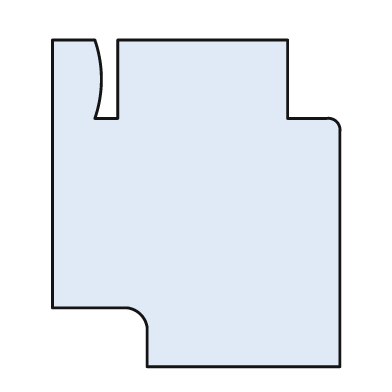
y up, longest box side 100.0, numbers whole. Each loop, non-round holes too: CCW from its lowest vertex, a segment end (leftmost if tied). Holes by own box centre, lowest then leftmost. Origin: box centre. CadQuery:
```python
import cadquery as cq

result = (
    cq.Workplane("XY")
    .moveTo(-15.0, -50.0)
    .lineTo(44.0, -50.0)
    .lineTo(44.0, 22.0)
    .threePointArc((43.0, 25.0), (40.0, 26.0))
    .lineTo(28.0, 26.0)
    .lineTo(28.0, 50.0)
    .lineTo(-24.0, 50.0)
    .lineTo(-24.0, 26.0)
    .lineTo(-31.0, 26.0)
    .threePointArc((-29.0, 38.0), (-31.0, 50.0))
    .lineTo(-44.0, 50.0)
    .lineTo(-44.0, -32.0)
    .lineTo(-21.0, -32.0)
    .threePointArc((-17.0, -34.0), (-15.0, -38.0))
    .close()
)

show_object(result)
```